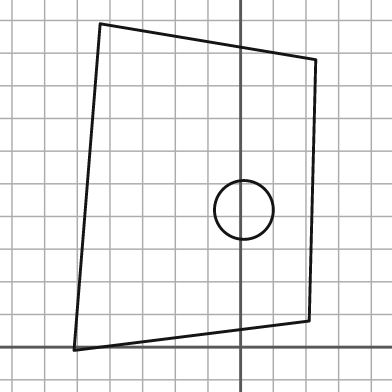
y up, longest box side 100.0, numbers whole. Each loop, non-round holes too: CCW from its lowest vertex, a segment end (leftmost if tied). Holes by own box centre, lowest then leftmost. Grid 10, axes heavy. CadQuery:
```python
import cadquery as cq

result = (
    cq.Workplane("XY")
    .moveTo(-51.0, -1.0)
    .lineTo(21.0, 8.0)
    .lineTo(23.0, 88.0)
    .lineTo(-43.0, 99.0)
    .close()
    .moveTo(1.0, 42.0)
    .circle(9.0)
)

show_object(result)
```